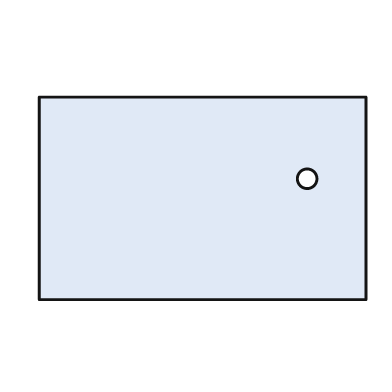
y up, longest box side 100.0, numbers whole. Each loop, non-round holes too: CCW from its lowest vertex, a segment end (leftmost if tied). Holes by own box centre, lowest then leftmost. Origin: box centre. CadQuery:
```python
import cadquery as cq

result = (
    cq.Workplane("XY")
    .moveTo(-50.0, -31.0)
    .lineTo(50.0, -31.0)
    .lineTo(50.0, 31.0)
    .lineTo(-50.0, 31.0)
    .close()
    .moveTo(32.0, 6.0)
    .circle(3.0)
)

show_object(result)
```